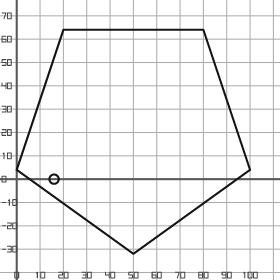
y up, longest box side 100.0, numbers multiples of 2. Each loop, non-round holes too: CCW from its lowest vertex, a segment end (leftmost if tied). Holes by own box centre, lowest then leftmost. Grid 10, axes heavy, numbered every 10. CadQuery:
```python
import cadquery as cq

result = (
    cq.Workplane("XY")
    .moveTo(50.0, -32.0)
    .lineTo(100.0, 4.0)
    .lineTo(80.0, 64.0)
    .lineTo(20.0, 64.0)
    .lineTo(0.0, 4.0)
    .close()
    .moveTo(16.0, 0.0)
    .circle(2.0)
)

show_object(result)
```